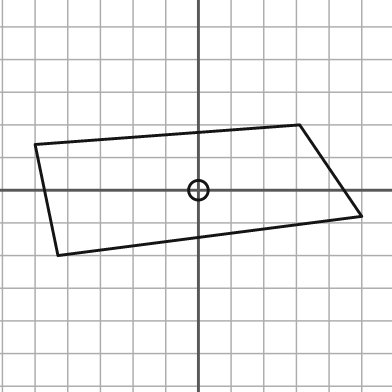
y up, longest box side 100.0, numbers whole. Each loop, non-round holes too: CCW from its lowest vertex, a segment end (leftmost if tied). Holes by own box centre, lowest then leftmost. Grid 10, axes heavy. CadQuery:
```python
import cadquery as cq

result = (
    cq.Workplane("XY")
    .moveTo(-43.0, -20.0)
    .lineTo(50.0, -8.0)
    .lineTo(31.0, 20.0)
    .lineTo(-50.0, 14.0)
    .close()
    .moveTo(0.0, 0.0)
    .circle(3.0)
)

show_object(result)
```